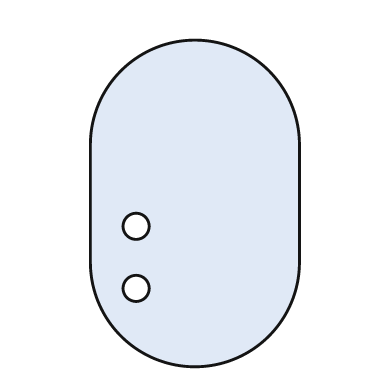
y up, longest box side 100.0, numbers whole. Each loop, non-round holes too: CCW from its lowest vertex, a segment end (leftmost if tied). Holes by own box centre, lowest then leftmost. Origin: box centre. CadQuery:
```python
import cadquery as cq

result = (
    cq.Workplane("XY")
    .moveTo(-32.0, -18.0)
    .threePointArc((0.0, -50.0), (32.0, -18.0))
    .lineTo(32.0, 18.0)
    .threePointArc((0.0, 50.0), (-32.0, 18.0))
    .close()
    .moveTo(-18.0, -26.0)
    .circle(4.0)
    .moveTo(-18.0, -7.0)
    .circle(4.0)
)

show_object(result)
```